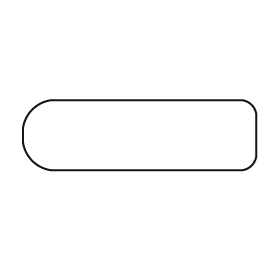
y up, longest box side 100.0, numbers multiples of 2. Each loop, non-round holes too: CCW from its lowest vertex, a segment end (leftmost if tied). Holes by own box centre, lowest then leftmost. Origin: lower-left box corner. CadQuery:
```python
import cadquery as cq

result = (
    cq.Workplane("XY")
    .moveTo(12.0, 0.0)
    .lineTo(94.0, 0.0)
    .threePointArc((98.0, 2.0), (100.0, 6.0))
    .lineTo(100.0, 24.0)
    .threePointArc((98.0, 28.0), (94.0, 30.0))
    .lineTo(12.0, 30.0)
    .threePointArc((4.0, 26.0), (0.0, 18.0))
    .lineTo(0.0, 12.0)
    .threePointArc((4.0, 4.0), (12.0, 0.0))
    .close()
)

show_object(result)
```